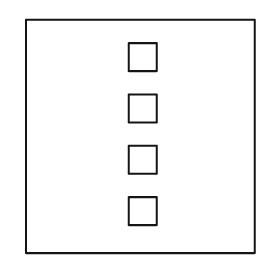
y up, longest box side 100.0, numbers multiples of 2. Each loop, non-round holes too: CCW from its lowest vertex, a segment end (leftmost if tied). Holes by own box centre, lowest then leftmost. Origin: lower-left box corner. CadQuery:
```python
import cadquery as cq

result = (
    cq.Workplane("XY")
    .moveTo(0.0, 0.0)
    .lineTo(98.0, 0.0)
    .lineTo(98.0, 100.0)
    .lineTo(0.0, 100.0)
    .close()
    .moveTo(44.0, 12.0)
    .lineTo(56.0, 12.0)
    .lineTo(56.0, 24.0)
    .lineTo(44.0, 24.0)
    .close()
    .moveTo(44.0, 34.0)
    .lineTo(56.0, 34.0)
    .lineTo(56.0, 46.0)
    .lineTo(44.0, 46.0)
    .close()
    .moveTo(44.0, 56.0)
    .lineTo(56.0, 56.0)
    .lineTo(56.0, 68.0)
    .lineTo(44.0, 68.0)
    .close()
    .moveTo(44.0, 78.0)
    .lineTo(56.0, 78.0)
    .lineTo(56.0, 90.0)
    .lineTo(44.0, 90.0)
    .close()
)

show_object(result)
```